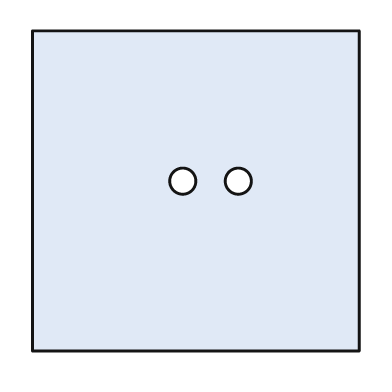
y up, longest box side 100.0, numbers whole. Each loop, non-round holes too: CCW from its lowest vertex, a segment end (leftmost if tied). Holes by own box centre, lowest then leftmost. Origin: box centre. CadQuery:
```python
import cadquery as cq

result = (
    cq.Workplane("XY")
    .moveTo(-50.0, -49.0)
    .lineTo(50.0, -49.0)
    .lineTo(50.0, 49.0)
    .lineTo(-50.0, 49.0)
    .close()
    .moveTo(-4.0, 3.0)
    .circle(4.0)
    .moveTo(13.0, 3.0)
    .circle(4.0)
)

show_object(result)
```